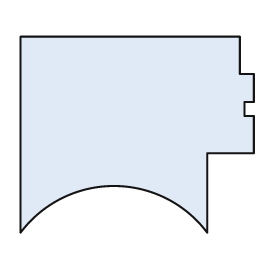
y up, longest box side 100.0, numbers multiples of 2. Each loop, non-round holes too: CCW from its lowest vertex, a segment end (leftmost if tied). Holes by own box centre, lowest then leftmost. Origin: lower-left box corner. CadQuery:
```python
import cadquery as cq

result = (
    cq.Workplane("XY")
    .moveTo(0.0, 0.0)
    .threePointArc((40.0, 20.0), (80.0, 0.0))
    .lineTo(80.0, 34.0)
    .lineTo(100.0, 34.0)
    .lineTo(100.0, 50.0)
    .lineTo(96.0, 50.0)
    .lineTo(96.0, 56.0)
    .lineTo(100.0, 56.0)
    .lineTo(100.0, 68.0)
    .lineTo(94.0, 68.0)
    .lineTo(94.0, 84.0)
    .lineTo(0.0, 84.0)
    .close()
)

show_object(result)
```